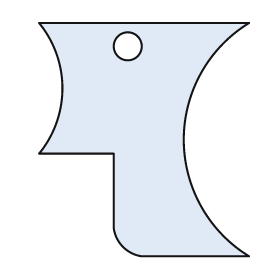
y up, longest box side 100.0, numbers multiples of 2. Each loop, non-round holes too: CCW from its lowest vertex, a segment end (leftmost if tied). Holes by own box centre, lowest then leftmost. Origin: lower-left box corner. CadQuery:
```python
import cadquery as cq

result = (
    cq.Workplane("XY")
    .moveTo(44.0, 0.0)
    .lineTo(90.0, 0.0)
    .threePointArc((62.0, 50.0), (90.0, 100.0))
    .lineTo(0.0, 100.0)
    .threePointArc((10.0, 72.0), (0.0, 44.0))
    .lineTo(32.0, 44.0)
    .lineTo(32.0, 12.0)
    .threePointArc((36.0, 4.0), (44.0, 0.0))
    .close()
    .moveTo(38.0, 90.0)
    .circle(6.0)
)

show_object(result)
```